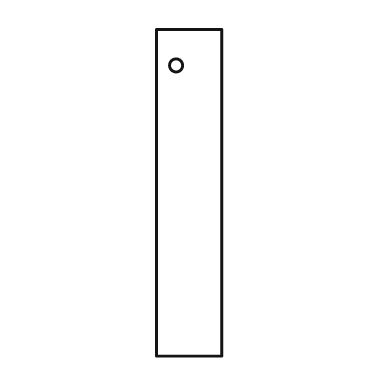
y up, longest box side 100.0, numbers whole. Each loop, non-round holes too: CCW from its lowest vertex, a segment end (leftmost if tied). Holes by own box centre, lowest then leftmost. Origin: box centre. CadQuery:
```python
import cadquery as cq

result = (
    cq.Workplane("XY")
    .moveTo(-10.0, -50.0)
    .lineTo(10.0, -50.0)
    .lineTo(10.0, 50.0)
    .lineTo(-10.0, 50.0)
    .close()
    .moveTo(-4.0, 39.0)
    .circle(2.0)
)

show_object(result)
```